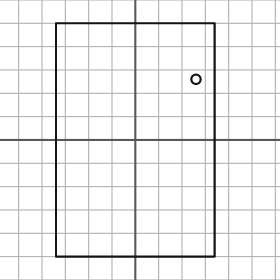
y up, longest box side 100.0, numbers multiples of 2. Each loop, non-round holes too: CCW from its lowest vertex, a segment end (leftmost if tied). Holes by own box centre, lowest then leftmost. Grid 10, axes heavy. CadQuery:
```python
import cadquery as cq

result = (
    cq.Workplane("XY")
    .moveTo(-34.0, -50.0)
    .lineTo(34.0, -50.0)
    .lineTo(34.0, 50.0)
    .lineTo(-34.0, 50.0)
    .close()
    .moveTo(26.0, 26.0)
    .circle(2.0)
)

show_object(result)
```